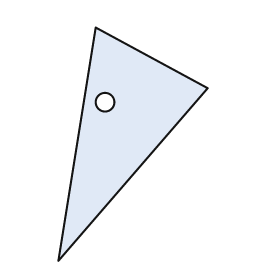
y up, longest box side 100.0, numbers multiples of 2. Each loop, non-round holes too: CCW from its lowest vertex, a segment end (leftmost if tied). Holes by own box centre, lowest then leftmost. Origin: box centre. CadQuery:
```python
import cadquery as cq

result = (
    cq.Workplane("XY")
    .moveTo(-32.0, -50.0)
    .lineTo(32.0, 24.0)
    .lineTo(-16.0, 50.0)
    .close()
    .moveTo(-12.0, 18.0)
    .circle(4.0)
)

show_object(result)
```